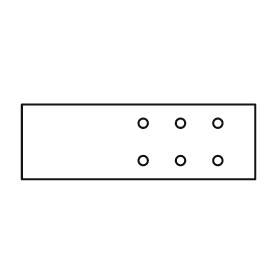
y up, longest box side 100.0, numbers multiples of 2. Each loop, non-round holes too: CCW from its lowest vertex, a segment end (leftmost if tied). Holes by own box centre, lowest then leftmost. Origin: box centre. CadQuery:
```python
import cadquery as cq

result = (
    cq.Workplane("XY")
    .moveTo(-50.0, -16.0)
    .lineTo(50.0, -16.0)
    .lineTo(50.0, 16.0)
    .lineTo(-50.0, 16.0)
    .close()
    .moveTo(2.0, -8.0)
    .circle(2.0)
    .moveTo(18.0, -8.0)
    .circle(2.0)
    .moveTo(34.0, -8.0)
    .circle(2.0)
    .moveTo(2.0, 8.0)
    .circle(2.0)
    .moveTo(18.0, 8.0)
    .circle(2.0)
    .moveTo(34.0, 8.0)
    .circle(2.0)
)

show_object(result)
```